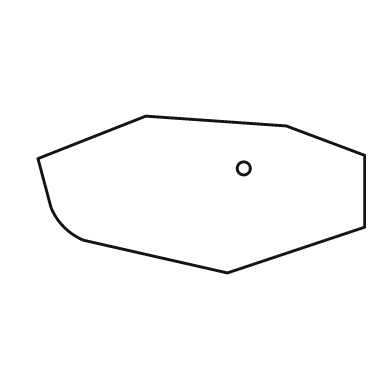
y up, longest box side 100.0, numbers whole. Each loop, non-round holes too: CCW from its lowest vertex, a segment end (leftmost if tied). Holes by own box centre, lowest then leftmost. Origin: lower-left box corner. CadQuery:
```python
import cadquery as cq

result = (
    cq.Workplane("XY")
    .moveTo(58.0, 0.0)
    .lineTo(100.0, 14.0)
    .lineTo(100.0, 36.0)
    .lineTo(76.0, 45.0)
    .lineTo(33.0, 48.0)
    .lineTo(0.0, 35.0)
    .lineTo(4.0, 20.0)
    .threePointArc((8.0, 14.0), (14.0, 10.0))
    .close()
    .moveTo(63.0, 32.0)
    .circle(2.0)
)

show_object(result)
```